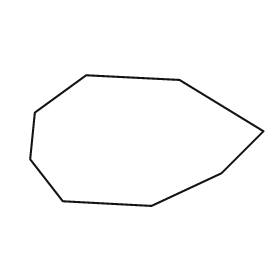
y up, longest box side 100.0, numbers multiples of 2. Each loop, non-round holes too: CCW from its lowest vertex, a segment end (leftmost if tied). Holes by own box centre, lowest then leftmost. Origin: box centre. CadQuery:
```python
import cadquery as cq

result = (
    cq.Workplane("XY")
    .moveTo(2.0, -28.0)
    .lineTo(32.0, -14.0)
    .lineTo(50.0, 4.0)
    .lineTo(14.0, 26.0)
    .lineTo(-26.0, 28.0)
    .lineTo(-48.0, 12.0)
    .lineTo(-50.0, -8.0)
    .lineTo(-36.0, -26.0)
    .close()
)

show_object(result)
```